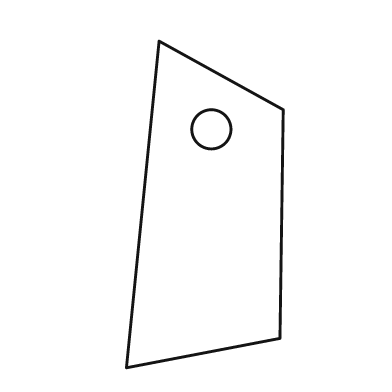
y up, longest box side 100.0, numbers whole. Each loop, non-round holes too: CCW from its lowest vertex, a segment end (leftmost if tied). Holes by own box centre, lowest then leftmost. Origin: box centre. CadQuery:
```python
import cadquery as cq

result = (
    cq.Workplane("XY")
    .moveTo(-24.0, -50.0)
    .lineTo(23.0, -41.0)
    .lineTo(24.0, 29.0)
    .lineTo(-14.0, 50.0)
    .close()
    .moveTo(2.0, 23.0)
    .circle(6.0)
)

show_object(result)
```